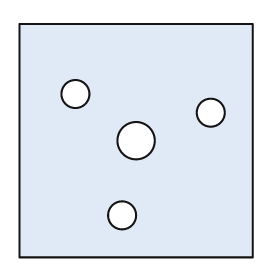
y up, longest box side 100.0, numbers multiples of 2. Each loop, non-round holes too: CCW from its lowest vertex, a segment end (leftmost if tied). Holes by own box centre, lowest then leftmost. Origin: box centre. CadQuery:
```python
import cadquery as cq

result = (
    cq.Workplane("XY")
    .moveTo(-50.0, -50.0)
    .lineTo(50.0, -50.0)
    .lineTo(50.0, 50.0)
    .lineTo(-50.0, 50.0)
    .close()
    .moveTo(-6.0, -32.0)
    .circle(6.0)
    .moveTo(0.0, 0.0)
    .circle(8.0)
    .moveTo(32.0, 12.0)
    .circle(6.0)
    .moveTo(-26.0, 20.0)
    .circle(6.0)
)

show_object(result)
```